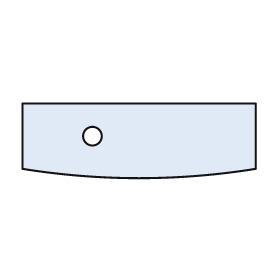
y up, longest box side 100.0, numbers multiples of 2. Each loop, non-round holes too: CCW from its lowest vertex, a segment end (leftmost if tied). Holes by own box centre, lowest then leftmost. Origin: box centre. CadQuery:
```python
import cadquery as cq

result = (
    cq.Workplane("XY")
    .moveTo(-50.0, -12.0)
    .threePointArc((0.0, -16.0), (50.0, -12.0))
    .lineTo(50.0, 16.0)
    .lineTo(-50.0, 16.0)
    .close()
    .moveTo(-20.0, 2.0)
    .circle(4.0)
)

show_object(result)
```